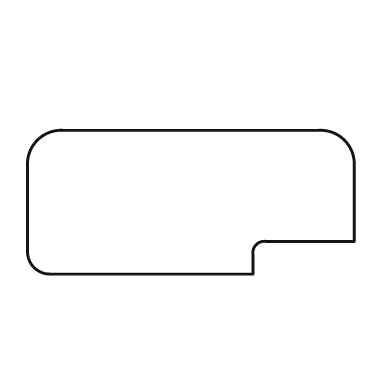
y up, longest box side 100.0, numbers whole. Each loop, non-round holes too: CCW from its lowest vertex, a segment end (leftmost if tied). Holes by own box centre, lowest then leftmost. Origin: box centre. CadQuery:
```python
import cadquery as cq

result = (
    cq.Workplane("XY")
    .moveTo(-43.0, -22.0)
    .lineTo(19.0, -22.0)
    .lineTo(19.0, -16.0)
    .threePointArc((20.0, -13.0), (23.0, -12.0))
    .lineTo(50.0, -12.0)
    .lineTo(50.0, 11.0)
    .threePointArc((47.0, 19.0), (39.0, 22.0))
    .lineTo(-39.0, 22.0)
    .threePointArc((-47.0, 19.0), (-50.0, 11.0))
    .lineTo(-50.0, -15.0)
    .threePointArc((-48.0, -20.0), (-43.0, -22.0))
    .close()
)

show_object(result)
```